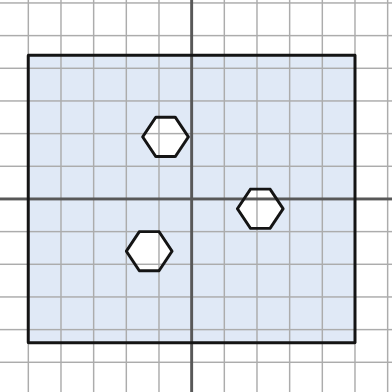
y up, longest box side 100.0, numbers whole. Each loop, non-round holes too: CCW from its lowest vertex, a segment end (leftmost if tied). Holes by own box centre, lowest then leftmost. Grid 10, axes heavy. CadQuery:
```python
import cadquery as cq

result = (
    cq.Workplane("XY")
    .moveTo(-50.0, -44.0)
    .lineTo(50.0, -44.0)
    .lineTo(50.0, 44.0)
    .lineTo(-50.0, 44.0)
    .close()
    .moveTo(-16.0, -22.0)
    .lineTo(-10.0, -22.0)
    .lineTo(-6.0, -16.0)
    .lineTo(-10.0, -10.0)
    .lineTo(-16.0, -10.0)
    .lineTo(-20.0, -16.0)
    .close()
    .moveTo(18.0, -9.0)
    .lineTo(24.0, -9.0)
    .lineTo(28.0, -3.0)
    .lineTo(24.0, 3.0)
    .lineTo(18.0, 3.0)
    .lineTo(14.0, -3.0)
    .close()
    .moveTo(-11.0, 13.0)
    .lineTo(-5.0, 13.0)
    .lineTo(-1.0, 19.0)
    .lineTo(-5.0, 25.0)
    .lineTo(-11.0, 25.0)
    .lineTo(-15.0, 19.0)
    .close()
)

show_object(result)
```